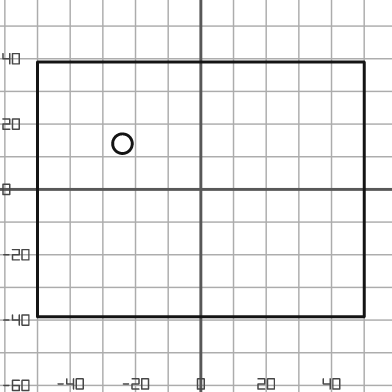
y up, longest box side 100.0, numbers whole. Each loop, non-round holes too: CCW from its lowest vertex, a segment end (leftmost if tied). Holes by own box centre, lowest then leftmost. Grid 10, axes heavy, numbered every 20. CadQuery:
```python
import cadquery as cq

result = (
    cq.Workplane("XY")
    .moveTo(-50.0, -39.0)
    .lineTo(50.0, -39.0)
    .lineTo(50.0, 39.0)
    .lineTo(-50.0, 39.0)
    .close()
    .moveTo(-24.0, 14.0)
    .circle(3.0)
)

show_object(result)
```